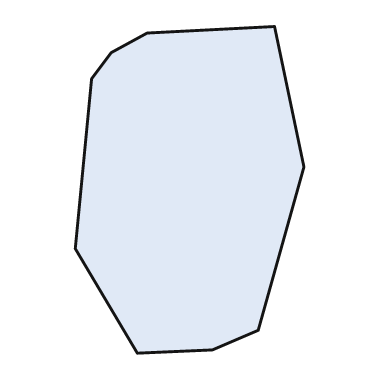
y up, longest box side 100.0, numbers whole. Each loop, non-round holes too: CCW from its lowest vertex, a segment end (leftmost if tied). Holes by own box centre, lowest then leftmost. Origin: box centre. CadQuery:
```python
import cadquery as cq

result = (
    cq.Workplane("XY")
    .moveTo(-16.0, -50.0)
    .lineTo(7.0, -49.0)
    .lineTo(21.0, -43.0)
    .lineTo(35.0, 7.0)
    .lineTo(26.0, 50.0)
    .lineTo(-13.0, 48.0)
    .lineTo(-24.0, 42.0)
    .lineTo(-30.0, 34.0)
    .lineTo(-35.0, -18.0)
    .close()
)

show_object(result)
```